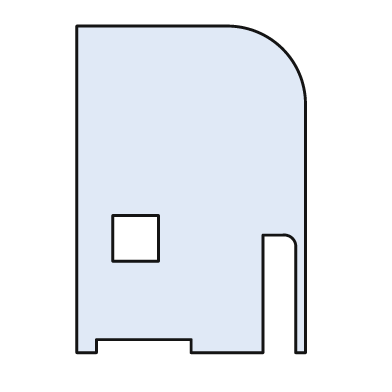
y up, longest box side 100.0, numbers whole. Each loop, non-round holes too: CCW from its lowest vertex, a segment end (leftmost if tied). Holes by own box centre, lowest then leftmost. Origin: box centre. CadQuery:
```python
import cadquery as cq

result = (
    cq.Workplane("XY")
    .moveTo(-35.0, -50.0)
    .lineTo(-29.0, -50.0)
    .lineTo(-29.0, -46.0)
    .lineTo(0.0, -46.0)
    .lineTo(0.0, -50.0)
    .lineTo(22.0, -50.0)
    .lineTo(22.0, -14.0)
    .lineTo(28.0, -14.0)
    .threePointArc((31.0, -15.0), (32.0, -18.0))
    .lineTo(32.0, -50.0)
    .lineTo(35.0, -50.0)
    .lineTo(35.0, 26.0)
    .threePointArc((28.0, 43.0), (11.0, 50.0))
    .lineTo(-35.0, 50.0)
    .close()
    .moveTo(-24.0, -22.0)
    .lineTo(-10.0, -22.0)
    .lineTo(-10.0, -8.0)
    .lineTo(-24.0, -8.0)
    .close()
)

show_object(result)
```